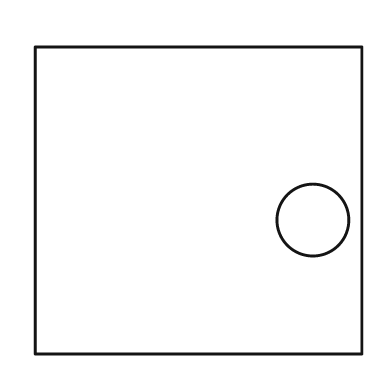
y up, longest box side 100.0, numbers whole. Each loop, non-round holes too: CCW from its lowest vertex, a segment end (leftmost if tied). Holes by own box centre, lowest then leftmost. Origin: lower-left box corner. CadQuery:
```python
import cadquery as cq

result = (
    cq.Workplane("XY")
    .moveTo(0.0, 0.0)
    .lineTo(100.0, 0.0)
    .lineTo(100.0, 94.0)
    .lineTo(0.0, 94.0)
    .close()
    .moveTo(85.0, 41.0)
    .circle(11.0)
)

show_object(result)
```